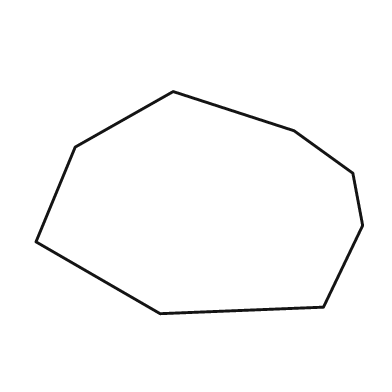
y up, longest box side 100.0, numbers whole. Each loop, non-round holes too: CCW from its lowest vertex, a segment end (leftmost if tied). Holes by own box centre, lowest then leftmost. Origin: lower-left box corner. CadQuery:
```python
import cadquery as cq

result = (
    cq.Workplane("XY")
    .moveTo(38.0, 0.0)
    .lineTo(88.0, 2.0)
    .lineTo(100.0, 27.0)
    .lineTo(97.0, 43.0)
    .lineTo(79.0, 56.0)
    .lineTo(42.0, 68.0)
    .lineTo(12.0, 51.0)
    .lineTo(0.0, 22.0)
    .close()
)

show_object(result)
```